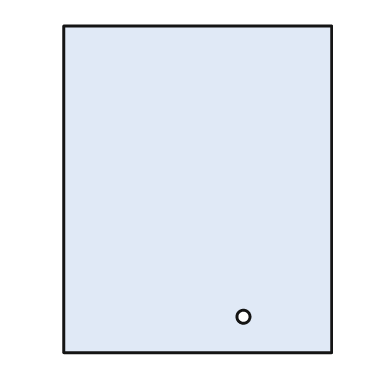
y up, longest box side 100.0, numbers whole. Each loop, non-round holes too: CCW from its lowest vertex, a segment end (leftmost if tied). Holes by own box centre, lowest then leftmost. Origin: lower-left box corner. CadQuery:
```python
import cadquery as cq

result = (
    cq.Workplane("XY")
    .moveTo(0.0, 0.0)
    .lineTo(82.0, 0.0)
    .lineTo(82.0, 100.0)
    .lineTo(0.0, 100.0)
    .close()
    .moveTo(55.0, 11.0)
    .circle(2.0)
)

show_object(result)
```